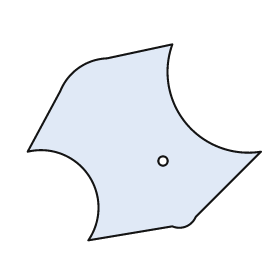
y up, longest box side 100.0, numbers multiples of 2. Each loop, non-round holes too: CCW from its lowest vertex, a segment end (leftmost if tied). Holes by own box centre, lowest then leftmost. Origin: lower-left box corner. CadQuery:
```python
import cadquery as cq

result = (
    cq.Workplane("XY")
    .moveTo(26.0, 0.0)
    .lineTo(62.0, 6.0)
    .threePointArc((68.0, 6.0), (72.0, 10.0))
    .lineTo(100.0, 38.0)
    .threePointArc((68.0, 50.0), (62.0, 84.0))
    .lineTo(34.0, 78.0)
    .threePointArc((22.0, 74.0), (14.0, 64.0))
    .lineTo(0.0, 38.0)
    .threePointArc((26.0, 28.0), (26.0, 0.0))
    .close()
    .moveTo(58.0, 34.0)
    .circle(2.0)
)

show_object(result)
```